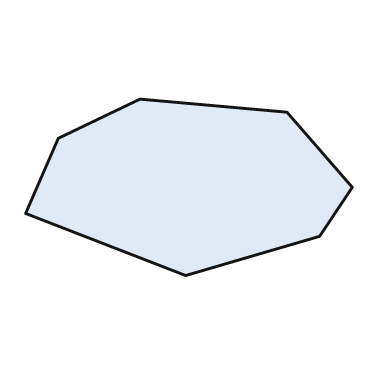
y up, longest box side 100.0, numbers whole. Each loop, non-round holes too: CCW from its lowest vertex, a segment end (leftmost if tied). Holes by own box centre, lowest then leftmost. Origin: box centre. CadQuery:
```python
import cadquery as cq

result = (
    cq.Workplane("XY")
    .moveTo(-1.0, -27.0)
    .lineTo(40.0, -15.0)
    .lineTo(50.0, 0.0)
    .lineTo(30.0, 23.0)
    .lineTo(-15.0, 27.0)
    .lineTo(-40.0, 15.0)
    .lineTo(-50.0, -8.0)
    .close()
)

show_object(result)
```